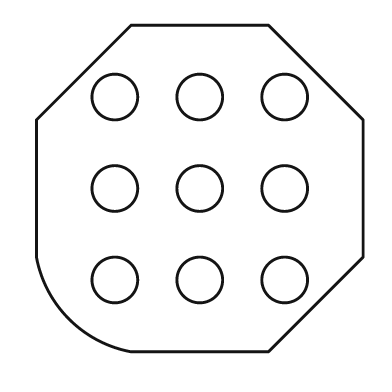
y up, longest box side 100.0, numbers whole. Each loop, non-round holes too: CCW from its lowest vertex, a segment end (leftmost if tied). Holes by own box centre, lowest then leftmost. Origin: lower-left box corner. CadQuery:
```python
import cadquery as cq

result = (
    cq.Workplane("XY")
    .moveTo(29.0, 0.0)
    .lineTo(71.0, 0.0)
    .lineTo(100.0, 29.0)
    .lineTo(100.0, 71.0)
    .lineTo(71.0, 100.0)
    .lineTo(29.0, 100.0)
    .lineTo(0.0, 71.0)
    .lineTo(0.0, 29.0)
    .threePointArc((10.0, 10.0), (29.0, 0.0))
    .close()
    .moveTo(24.0, 22.0)
    .circle(7.0)
    .moveTo(50.0, 22.0)
    .circle(7.0)
    .moveTo(76.0, 22.0)
    .circle(7.0)
    .moveTo(24.0, 50.0)
    .circle(7.0)
    .moveTo(50.0, 50.0)
    .circle(7.0)
    .moveTo(76.0, 50.0)
    .circle(7.0)
    .moveTo(24.0, 78.0)
    .circle(7.0)
    .moveTo(50.0, 78.0)
    .circle(7.0)
    .moveTo(76.0, 78.0)
    .circle(7.0)
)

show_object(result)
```